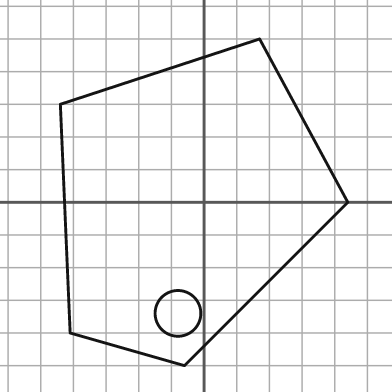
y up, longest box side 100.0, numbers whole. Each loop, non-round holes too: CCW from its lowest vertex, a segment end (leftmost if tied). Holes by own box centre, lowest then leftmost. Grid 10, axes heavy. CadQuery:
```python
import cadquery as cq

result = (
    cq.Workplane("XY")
    .moveTo(-6.0, -50.0)
    .lineTo(44.0, 0.0)
    .lineTo(17.0, 50.0)
    .lineTo(-44.0, 30.0)
    .lineTo(-41.0, -40.0)
    .close()
    .moveTo(-8.0, -34.0)
    .circle(7.0)
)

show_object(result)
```